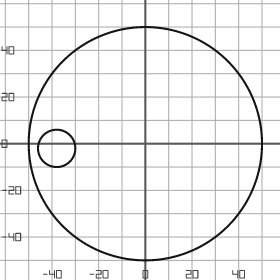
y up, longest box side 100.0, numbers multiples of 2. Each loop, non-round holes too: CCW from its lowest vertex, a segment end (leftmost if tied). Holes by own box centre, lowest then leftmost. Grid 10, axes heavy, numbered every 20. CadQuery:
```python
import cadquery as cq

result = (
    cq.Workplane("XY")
    .moveTo(0.0, 0.0)
    .circle(50.0)
    .moveTo(-38.0, -2.0)
    .circle(8.0)
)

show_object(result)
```